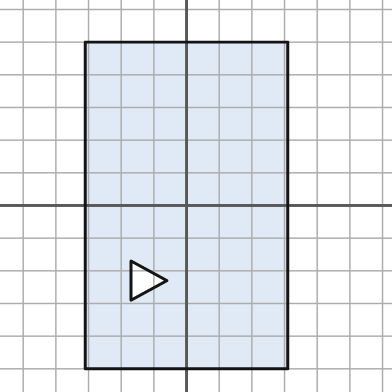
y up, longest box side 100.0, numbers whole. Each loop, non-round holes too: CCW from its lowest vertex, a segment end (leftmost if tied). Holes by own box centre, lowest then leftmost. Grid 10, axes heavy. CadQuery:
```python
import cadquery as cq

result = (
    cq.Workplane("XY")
    .moveTo(-31.0, -50.0)
    .lineTo(31.0, -50.0)
    .lineTo(31.0, 50.0)
    .lineTo(-31.0, 50.0)
    .close()
    .moveTo(-17.0, -29.0)
    .lineTo(-6.0, -23.0)
    .lineTo(-17.0, -17.0)
    .close()
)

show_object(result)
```